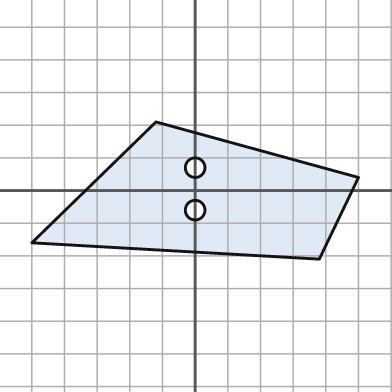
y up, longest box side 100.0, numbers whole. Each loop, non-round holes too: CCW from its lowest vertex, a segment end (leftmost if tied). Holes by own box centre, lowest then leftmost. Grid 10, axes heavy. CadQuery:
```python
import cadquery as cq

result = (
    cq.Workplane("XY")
    .moveTo(38.0, -21.0)
    .lineTo(50.0, 4.0)
    .lineTo(-12.0, 21.0)
    .lineTo(-50.0, -16.0)
    .close()
    .moveTo(0.0, -6.0)
    .circle(3.0)
    .moveTo(0.0, 7.0)
    .circle(3.0)
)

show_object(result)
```